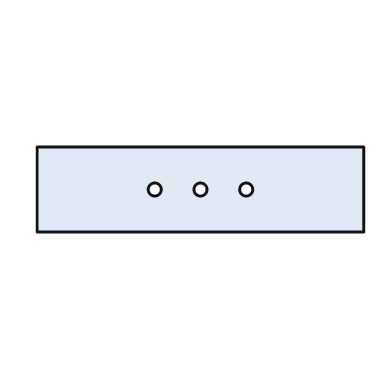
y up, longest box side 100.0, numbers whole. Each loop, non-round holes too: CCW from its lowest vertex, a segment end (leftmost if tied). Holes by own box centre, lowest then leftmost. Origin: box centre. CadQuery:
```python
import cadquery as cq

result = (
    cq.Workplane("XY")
    .moveTo(-50.0, -13.0)
    .lineTo(50.0, -13.0)
    .lineTo(50.0, 13.0)
    .lineTo(-50.0, 13.0)
    .close()
    .moveTo(-14.0, 0.0)
    .circle(2.0)
    .moveTo(0.0, 0.0)
    .circle(2.0)
    .moveTo(14.0, 0.0)
    .circle(2.0)
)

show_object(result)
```